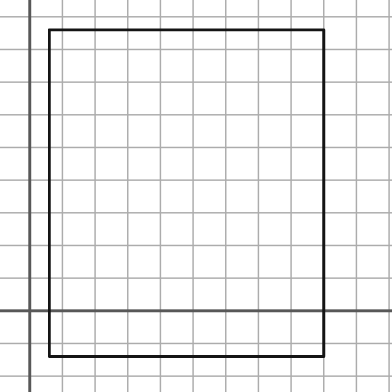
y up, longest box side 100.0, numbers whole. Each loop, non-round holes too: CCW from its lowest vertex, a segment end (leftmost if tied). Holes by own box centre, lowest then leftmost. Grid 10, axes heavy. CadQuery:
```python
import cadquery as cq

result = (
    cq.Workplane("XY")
    .moveTo(6.0, -14.0)
    .lineTo(90.0, -14.0)
    .lineTo(90.0, 86.0)
    .lineTo(6.0, 86.0)
    .close()
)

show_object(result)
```